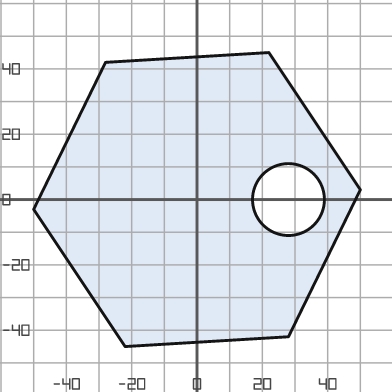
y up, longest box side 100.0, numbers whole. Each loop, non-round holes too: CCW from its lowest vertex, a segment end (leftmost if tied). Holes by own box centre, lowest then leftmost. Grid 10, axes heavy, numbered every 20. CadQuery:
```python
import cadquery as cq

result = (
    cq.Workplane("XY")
    .moveTo(-22.0, -45.0)
    .lineTo(28.0, -42.0)
    .lineTo(50.0, 3.0)
    .lineTo(22.0, 45.0)
    .lineTo(-28.0, 42.0)
    .lineTo(-50.0, -3.0)
    .close()
    .moveTo(28.0, 0.0)
    .circle(11.0)
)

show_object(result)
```